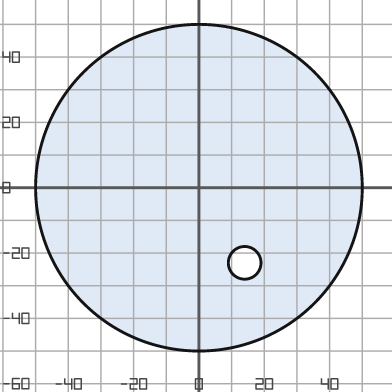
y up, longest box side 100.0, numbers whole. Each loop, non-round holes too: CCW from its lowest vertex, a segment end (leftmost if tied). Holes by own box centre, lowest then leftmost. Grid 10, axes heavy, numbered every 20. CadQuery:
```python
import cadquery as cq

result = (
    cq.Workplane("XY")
    .moveTo(0.0, 0.0)
    .circle(50.0)
    .moveTo(14.0, -23.0)
    .circle(5.0)
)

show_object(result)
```